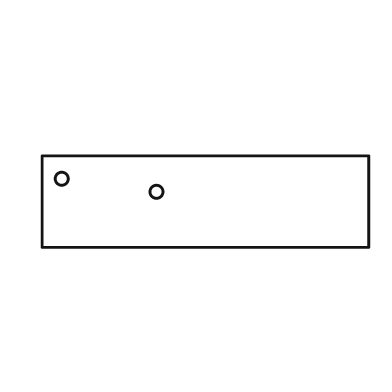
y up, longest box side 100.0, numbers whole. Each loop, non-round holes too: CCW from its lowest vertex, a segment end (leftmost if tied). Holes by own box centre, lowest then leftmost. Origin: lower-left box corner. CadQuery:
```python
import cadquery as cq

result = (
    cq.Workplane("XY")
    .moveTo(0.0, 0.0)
    .lineTo(100.0, 0.0)
    .lineTo(100.0, 28.0)
    .lineTo(0.0, 28.0)
    .close()
    .moveTo(35.0, 17.0)
    .circle(2.0)
    .moveTo(6.0, 21.0)
    .circle(2.0)
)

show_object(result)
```